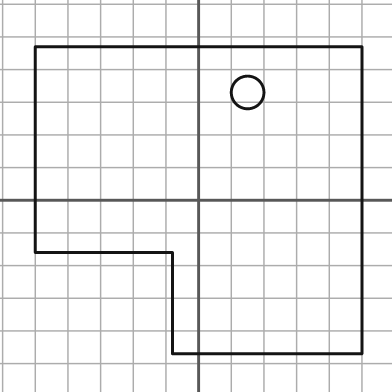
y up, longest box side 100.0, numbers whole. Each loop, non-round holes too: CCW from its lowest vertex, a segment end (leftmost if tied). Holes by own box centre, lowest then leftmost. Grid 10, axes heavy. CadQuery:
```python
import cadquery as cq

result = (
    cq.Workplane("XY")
    .moveTo(-8.0, -47.0)
    .lineTo(50.0, -47.0)
    .lineTo(50.0, 47.0)
    .lineTo(-50.0, 47.0)
    .lineTo(-50.0, -16.0)
    .lineTo(-8.0, -16.0)
    .close()
    .moveTo(15.0, 33.0)
    .circle(5.0)
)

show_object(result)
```